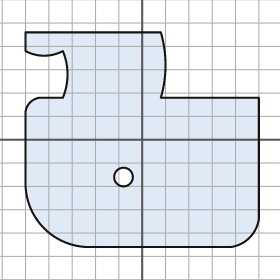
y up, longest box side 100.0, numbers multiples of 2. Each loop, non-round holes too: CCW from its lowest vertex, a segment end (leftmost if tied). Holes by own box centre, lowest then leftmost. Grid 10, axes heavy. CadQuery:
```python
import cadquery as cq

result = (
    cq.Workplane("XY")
    .moveTo(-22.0, -46.0)
    .lineTo(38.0, -46.0)
    .threePointArc((46.0, -42.0), (50.0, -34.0))
    .lineTo(50.0, 18.0)
    .lineTo(8.0, 18.0)
    .threePointArc((10.0, 32.0), (8.0, 46.0))
    .lineTo(-50.0, 46.0)
    .lineTo(-50.0, 38.0)
    .threePointArc((-42.0, 36.0), (-34.0, 38.0))
    .threePointArc((-32.0, 28.0), (-34.0, 18.0))
    .lineTo(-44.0, 18.0)
    .threePointArc((-48.0, 16.0), (-50.0, 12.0))
    .lineTo(-50.0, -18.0)
    .threePointArc((-42.0, -38.0), (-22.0, -46.0))
    .close()
    .moveTo(-8.0, -16.0)
    .circle(4.0)
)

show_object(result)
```